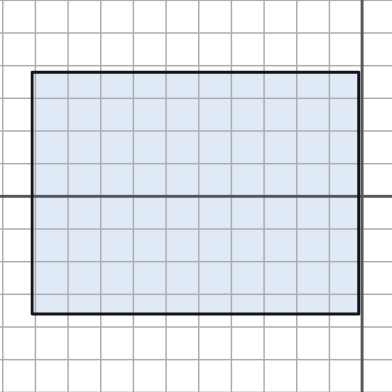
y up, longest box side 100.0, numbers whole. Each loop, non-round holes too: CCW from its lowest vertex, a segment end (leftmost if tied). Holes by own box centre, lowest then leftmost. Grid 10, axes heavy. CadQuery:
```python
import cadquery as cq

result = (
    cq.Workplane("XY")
    .moveTo(-101.0, -36.0)
    .lineTo(-1.0, -36.0)
    .lineTo(-1.0, 38.0)
    .lineTo(-101.0, 38.0)
    .close()
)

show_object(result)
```